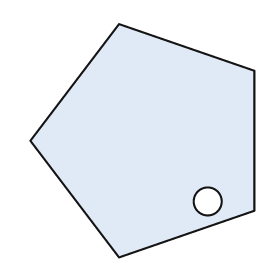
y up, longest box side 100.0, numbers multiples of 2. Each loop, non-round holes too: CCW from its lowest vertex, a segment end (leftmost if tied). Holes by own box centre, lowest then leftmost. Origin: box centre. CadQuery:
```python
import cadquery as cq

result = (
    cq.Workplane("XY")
    .moveTo(-10.0, -50.0)
    .lineTo(48.0, -30.0)
    .lineTo(48.0, 30.0)
    .lineTo(-10.0, 50.0)
    .lineTo(-48.0, 0.0)
    .close()
    .moveTo(28.0, -26.0)
    .circle(6.0)
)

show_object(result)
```